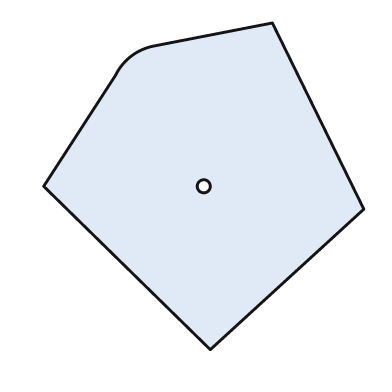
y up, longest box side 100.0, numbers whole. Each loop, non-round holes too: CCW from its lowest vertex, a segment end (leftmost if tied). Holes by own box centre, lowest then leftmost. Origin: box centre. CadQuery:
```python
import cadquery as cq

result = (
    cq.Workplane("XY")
    .moveTo(2.0, -50.0)
    .lineTo(49.0, -7.0)
    .lineTo(21.0, 50.0)
    .lineTo(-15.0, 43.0)
    .threePointArc((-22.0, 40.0), (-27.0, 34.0))
    .lineTo(-49.0, 0.0)
    .close()
    .moveTo(0.0, 0.0)
    .circle(2.0)
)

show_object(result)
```